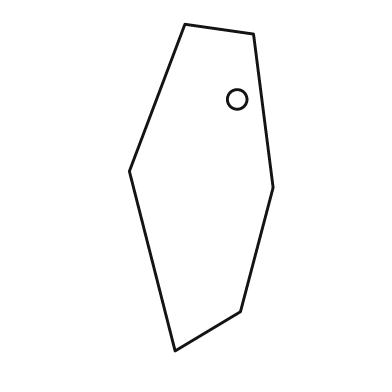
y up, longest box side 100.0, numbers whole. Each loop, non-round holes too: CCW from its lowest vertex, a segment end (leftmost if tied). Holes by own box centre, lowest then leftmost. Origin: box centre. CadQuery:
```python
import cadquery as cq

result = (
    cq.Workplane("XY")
    .moveTo(-8.0, -50.0)
    .lineTo(12.0, -38.0)
    .lineTo(22.0, 0.0)
    .lineTo(16.0, 47.0)
    .lineTo(-5.0, 50.0)
    .lineTo(-22.0, 5.0)
    .close()
    .moveTo(11.0, 27.0)
    .circle(3.0)
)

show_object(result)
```